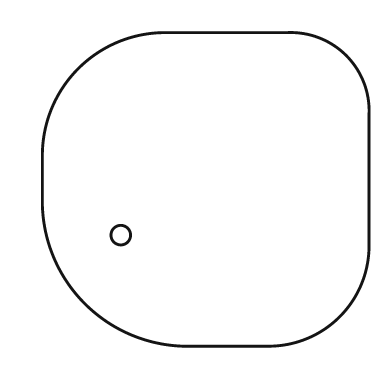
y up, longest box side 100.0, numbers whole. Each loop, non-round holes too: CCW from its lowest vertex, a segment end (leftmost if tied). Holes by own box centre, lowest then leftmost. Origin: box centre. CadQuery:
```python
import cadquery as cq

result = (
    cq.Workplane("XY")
    .moveTo(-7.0, -48.0)
    .lineTo(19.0, -48.0)
    .threePointArc((41.0, -39.0), (50.0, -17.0))
    .lineTo(50.0, 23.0)
    .threePointArc((43.0, 41.0), (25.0, 48.0))
    .lineTo(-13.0, 48.0)
    .threePointArc((-39.0, 37.0), (-50.0, 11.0))
    .lineTo(-50.0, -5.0)
    .threePointArc((-37.0, -35.0), (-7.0, -48.0))
    .close()
    .moveTo(-26.0, -14.0)
    .circle(3.0)
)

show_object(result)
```